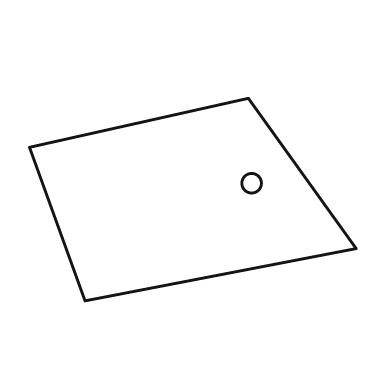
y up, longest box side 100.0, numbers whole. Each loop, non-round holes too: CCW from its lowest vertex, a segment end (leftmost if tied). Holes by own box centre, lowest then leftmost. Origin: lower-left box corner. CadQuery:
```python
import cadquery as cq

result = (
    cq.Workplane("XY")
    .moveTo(17.0, 0.0)
    .lineTo(100.0, 16.0)
    .lineTo(67.0, 62.0)
    .lineTo(0.0, 47.0)
    .close()
    .moveTo(68.0, 36.0)
    .circle(3.0)
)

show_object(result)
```